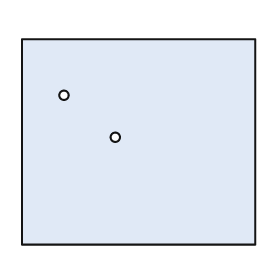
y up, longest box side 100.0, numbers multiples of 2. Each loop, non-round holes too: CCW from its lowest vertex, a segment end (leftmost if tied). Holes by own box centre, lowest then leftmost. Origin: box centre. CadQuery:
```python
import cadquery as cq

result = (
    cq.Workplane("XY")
    .moveTo(-50.0, -44.0)
    .lineTo(50.0, -44.0)
    .lineTo(50.0, 44.0)
    .lineTo(-50.0, 44.0)
    .close()
    .moveTo(-10.0, 2.0)
    .circle(2.0)
    .moveTo(-32.0, 20.0)
    .circle(2.0)
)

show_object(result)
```